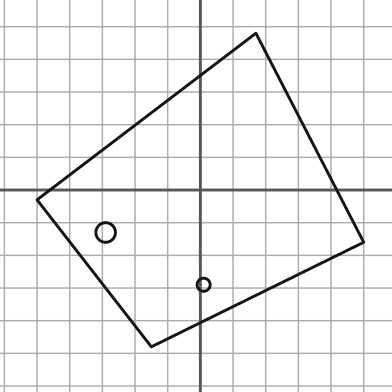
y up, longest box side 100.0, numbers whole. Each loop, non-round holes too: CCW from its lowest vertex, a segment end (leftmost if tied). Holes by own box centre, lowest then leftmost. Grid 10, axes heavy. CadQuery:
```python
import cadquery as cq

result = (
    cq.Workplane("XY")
    .moveTo(-15.0, -48.0)
    .lineTo(50.0, -16.0)
    .lineTo(17.0, 48.0)
    .lineTo(-50.0, -3.0)
    .close()
    .moveTo(1.0, -29.0)
    .circle(2.0)
    .moveTo(-29.0, -13.0)
    .circle(3.0)
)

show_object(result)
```